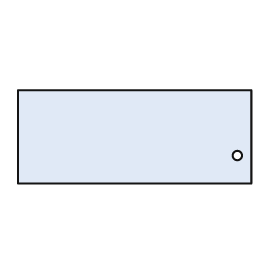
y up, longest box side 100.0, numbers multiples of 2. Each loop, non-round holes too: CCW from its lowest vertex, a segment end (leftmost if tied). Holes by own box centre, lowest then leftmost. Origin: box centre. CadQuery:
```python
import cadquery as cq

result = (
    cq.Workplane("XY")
    .moveTo(-50.0, -20.0)
    .lineTo(50.0, -20.0)
    .lineTo(50.0, 20.0)
    .lineTo(-50.0, 20.0)
    .close()
    .moveTo(44.0, -8.0)
    .circle(2.0)
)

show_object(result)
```